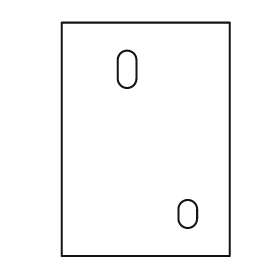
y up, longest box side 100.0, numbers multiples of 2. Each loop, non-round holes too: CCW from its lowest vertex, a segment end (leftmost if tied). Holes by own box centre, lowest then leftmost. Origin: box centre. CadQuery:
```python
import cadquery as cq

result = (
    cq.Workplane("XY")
    .moveTo(-36.0, -50.0)
    .lineTo(36.0, -50.0)
    .lineTo(36.0, 50.0)
    .lineTo(-36.0, 50.0)
    .close()
    .moveTo(14.0, -34.0)
    .threePointArc((18.0, -38.0), (22.0, -34.0))
    .lineTo(22.0, -30.0)
    .threePointArc((18.0, -26.0), (14.0, -30.0))
    .close()
    .moveTo(-12.0, 26.0)
    .threePointArc((-8.0, 22.0), (-4.0, 26.0))
    .lineTo(-4.0, 34.0)
    .threePointArc((-8.0, 38.0), (-12.0, 34.0))
    .close()
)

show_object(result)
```